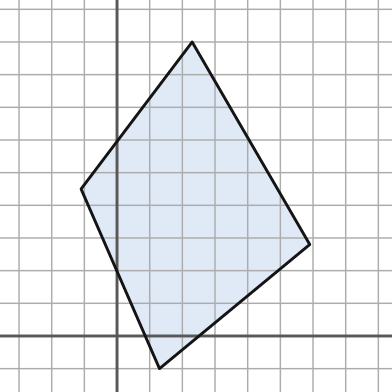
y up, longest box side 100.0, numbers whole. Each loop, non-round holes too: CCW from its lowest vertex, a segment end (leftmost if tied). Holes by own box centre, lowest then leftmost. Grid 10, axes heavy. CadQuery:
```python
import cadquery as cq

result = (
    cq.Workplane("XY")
    .moveTo(13.0, -10.0)
    .lineTo(59.0, 28.0)
    .lineTo(23.0, 90.0)
    .lineTo(-11.0, 45.0)
    .close()
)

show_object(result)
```